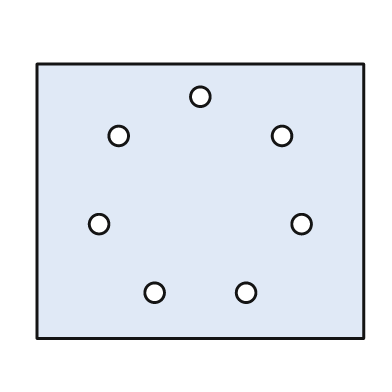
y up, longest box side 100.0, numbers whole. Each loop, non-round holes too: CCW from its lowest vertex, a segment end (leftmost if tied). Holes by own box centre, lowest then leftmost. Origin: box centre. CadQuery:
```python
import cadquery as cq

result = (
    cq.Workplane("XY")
    .moveTo(-50.0, -42.0)
    .lineTo(50.0, -42.0)
    .lineTo(50.0, 42.0)
    .lineTo(-50.0, 42.0)
    .close()
    .moveTo(-14.0, -28.0)
    .circle(3.0)
    .moveTo(14.0, -28.0)
    .circle(3.0)
    .moveTo(-31.0, -7.0)
    .circle(3.0)
    .moveTo(31.0, -7.0)
    .circle(3.0)
    .moveTo(-25.0, 20.0)
    .circle(3.0)
    .moveTo(25.0, 20.0)
    .circle(3.0)
    .moveTo(0.0, 32.0)
    .circle(3.0)
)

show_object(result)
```